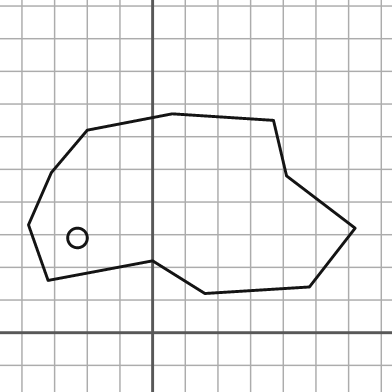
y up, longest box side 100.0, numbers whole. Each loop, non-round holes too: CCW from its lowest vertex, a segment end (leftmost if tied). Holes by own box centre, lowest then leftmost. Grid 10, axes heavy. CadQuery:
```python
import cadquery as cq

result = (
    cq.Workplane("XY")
    .moveTo(16.0, 12.0)
    .lineTo(48.0, 14.0)
    .lineTo(62.0, 32.0)
    .lineTo(41.0, 48.0)
    .lineTo(37.0, 65.0)
    .lineTo(6.0, 67.0)
    .lineTo(-20.0, 62.0)
    .lineTo(-31.0, 49.0)
    .lineTo(-38.0, 33.0)
    .lineTo(-32.0, 16.0)
    .lineTo(0.0, 22.0)
    .close()
    .moveTo(-23.0, 29.0)
    .circle(3.0)
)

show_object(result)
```